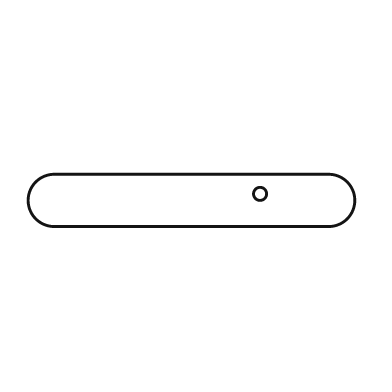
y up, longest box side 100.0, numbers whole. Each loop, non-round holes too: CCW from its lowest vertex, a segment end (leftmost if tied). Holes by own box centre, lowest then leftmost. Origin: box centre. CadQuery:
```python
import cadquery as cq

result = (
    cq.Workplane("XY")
    .moveTo(-42.0, -8.0)
    .lineTo(42.0, -8.0)
    .threePointArc((50.0, 0.0), (42.0, 8.0))
    .lineTo(-42.0, 8.0)
    .threePointArc((-50.0, 0.0), (-42.0, -8.0))
    .close()
    .moveTo(21.0, 2.0)
    .circle(2.0)
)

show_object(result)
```